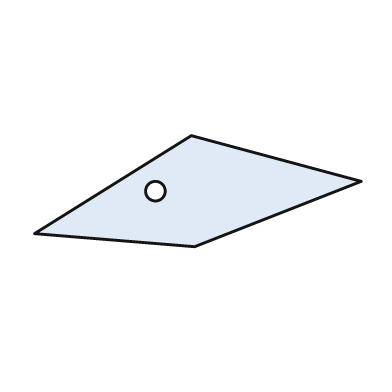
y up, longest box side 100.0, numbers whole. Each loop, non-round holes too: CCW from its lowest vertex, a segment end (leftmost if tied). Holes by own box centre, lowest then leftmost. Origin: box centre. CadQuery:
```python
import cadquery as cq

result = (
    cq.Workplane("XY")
    .moveTo(-1.0, -17.0)
    .lineTo(50.0, 3.0)
    .lineTo(-2.0, 17.0)
    .lineTo(-50.0, -13.0)
    .close()
    .moveTo(-13.0, 0.0)
    .circle(3.0)
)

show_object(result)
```